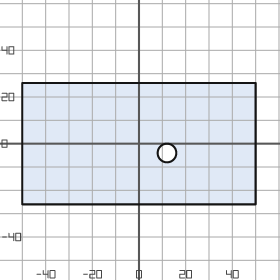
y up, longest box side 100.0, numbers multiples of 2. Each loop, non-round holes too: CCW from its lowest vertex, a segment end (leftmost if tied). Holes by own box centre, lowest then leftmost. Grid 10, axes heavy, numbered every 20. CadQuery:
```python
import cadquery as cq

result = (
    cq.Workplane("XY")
    .moveTo(-50.0, -26.0)
    .lineTo(50.0, -26.0)
    .lineTo(50.0, 26.0)
    .lineTo(-50.0, 26.0)
    .close()
    .moveTo(12.0, -4.0)
    .circle(4.0)
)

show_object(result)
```